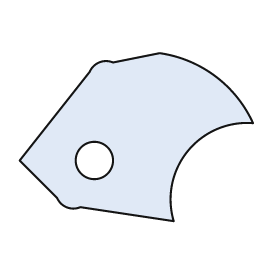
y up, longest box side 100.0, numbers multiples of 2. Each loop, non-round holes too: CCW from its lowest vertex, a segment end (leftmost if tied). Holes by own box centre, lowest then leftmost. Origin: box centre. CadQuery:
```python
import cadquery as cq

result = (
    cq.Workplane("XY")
    .moveTo(16.0, -36.0)
    .threePointArc((22.0, -6.0), (50.0, 6.0))
    .threePointArc((34.0, 26.0), (10.0, 36.0))
    .lineTo(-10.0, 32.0)
    .threePointArc((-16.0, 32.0), (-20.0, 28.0))
    .lineTo(-50.0, -10.0)
    .lineTo(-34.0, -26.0)
    .threePointArc((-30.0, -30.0), (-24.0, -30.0))
    .close()
    .moveTo(-18.0, -10.0)
    .circle(8.0)
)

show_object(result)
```